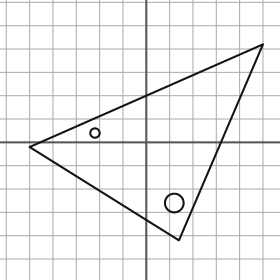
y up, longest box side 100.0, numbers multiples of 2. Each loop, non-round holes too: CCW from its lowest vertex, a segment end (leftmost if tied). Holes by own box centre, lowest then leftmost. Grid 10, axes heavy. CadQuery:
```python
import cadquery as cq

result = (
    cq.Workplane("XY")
    .moveTo(14.0, -42.0)
    .lineTo(50.0, 42.0)
    .lineTo(-50.0, -2.0)
    .close()
    .moveTo(12.0, -26.0)
    .circle(4.0)
    .moveTo(-22.0, 4.0)
    .circle(2.0)
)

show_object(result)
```